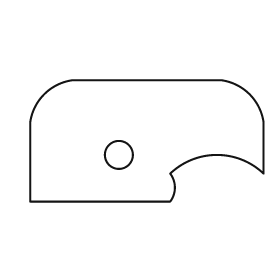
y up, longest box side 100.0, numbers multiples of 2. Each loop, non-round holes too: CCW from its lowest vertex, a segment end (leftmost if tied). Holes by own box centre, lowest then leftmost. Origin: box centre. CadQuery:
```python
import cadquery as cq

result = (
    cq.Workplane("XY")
    .moveTo(-50.0, -26.0)
    .lineTo(10.0, -26.0)
    .threePointArc((12.0, -20.0), (10.0, -14.0))
    .threePointArc((30.0, -6.0), (50.0, -14.0))
    .lineTo(50.0, 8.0)
    .threePointArc((44.0, 20.0), (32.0, 26.0))
    .lineTo(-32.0, 26.0)
    .threePointArc((-44.0, 20.0), (-50.0, 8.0))
    .close()
    .moveTo(-12.0, -6.0)
    .circle(6.0)
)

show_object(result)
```